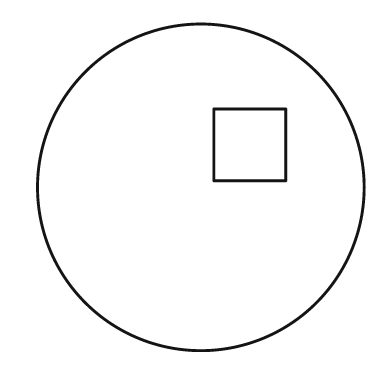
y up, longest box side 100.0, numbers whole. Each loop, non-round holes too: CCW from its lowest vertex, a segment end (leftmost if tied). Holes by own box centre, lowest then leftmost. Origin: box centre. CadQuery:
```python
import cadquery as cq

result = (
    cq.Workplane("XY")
    .moveTo(0.0, 0.0)
    .circle(50.0)
    .moveTo(4.0, 2.0)
    .lineTo(26.0, 2.0)
    .lineTo(26.0, 24.0)
    .lineTo(4.0, 24.0)
    .close()
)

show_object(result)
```